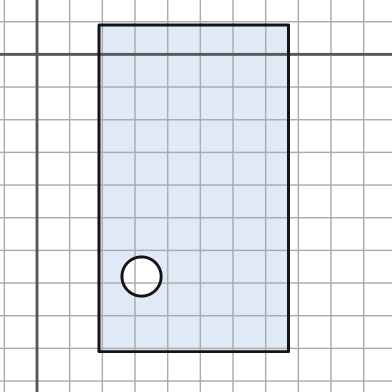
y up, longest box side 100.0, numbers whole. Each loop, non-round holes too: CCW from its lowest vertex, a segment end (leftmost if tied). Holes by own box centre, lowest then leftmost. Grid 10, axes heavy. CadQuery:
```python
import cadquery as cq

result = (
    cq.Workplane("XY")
    .moveTo(19.0, -91.0)
    .lineTo(77.0, -91.0)
    .lineTo(77.0, 9.0)
    .lineTo(19.0, 9.0)
    .close()
    .moveTo(32.0, -68.0)
    .circle(6.0)
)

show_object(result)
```